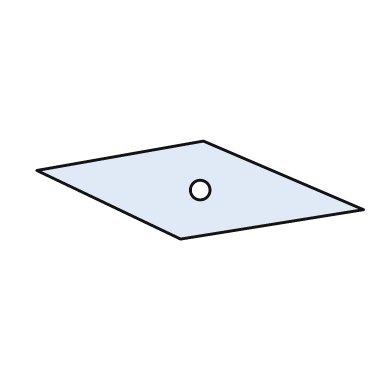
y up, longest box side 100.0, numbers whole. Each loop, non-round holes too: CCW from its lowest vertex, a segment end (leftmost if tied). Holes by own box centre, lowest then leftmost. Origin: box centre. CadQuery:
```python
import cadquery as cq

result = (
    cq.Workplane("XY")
    .moveTo(-6.0, -15.0)
    .lineTo(50.0, -6.0)
    .lineTo(1.0, 15.0)
    .lineTo(-50.0, 6.0)
    .close()
    .moveTo(0.0, 0.0)
    .circle(3.0)
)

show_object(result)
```